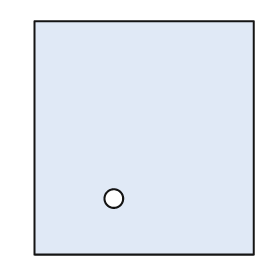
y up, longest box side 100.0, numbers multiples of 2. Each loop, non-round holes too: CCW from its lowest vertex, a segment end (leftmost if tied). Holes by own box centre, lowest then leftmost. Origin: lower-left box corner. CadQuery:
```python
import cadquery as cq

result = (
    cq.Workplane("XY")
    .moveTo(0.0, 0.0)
    .lineTo(94.0, 0.0)
    .lineTo(94.0, 100.0)
    .lineTo(0.0, 100.0)
    .close()
    .moveTo(34.0, 24.0)
    .circle(4.0)
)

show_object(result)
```